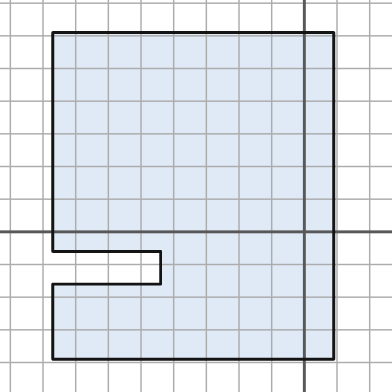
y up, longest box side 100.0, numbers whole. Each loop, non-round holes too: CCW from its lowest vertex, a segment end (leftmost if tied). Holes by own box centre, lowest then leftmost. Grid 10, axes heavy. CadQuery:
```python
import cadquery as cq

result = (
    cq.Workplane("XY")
    .moveTo(-77.0, -39.0)
    .lineTo(9.0, -39.0)
    .lineTo(9.0, 61.0)
    .lineTo(-77.0, 61.0)
    .lineTo(-77.0, -6.0)
    .lineTo(-44.0, -6.0)
    .lineTo(-44.0, -16.0)
    .lineTo(-77.0, -16.0)
    .close()
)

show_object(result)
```